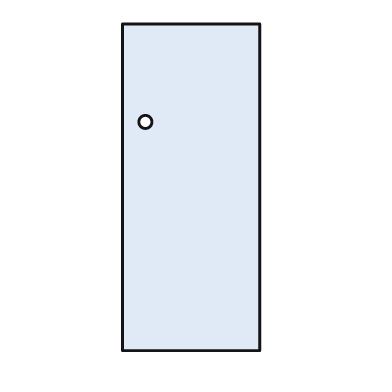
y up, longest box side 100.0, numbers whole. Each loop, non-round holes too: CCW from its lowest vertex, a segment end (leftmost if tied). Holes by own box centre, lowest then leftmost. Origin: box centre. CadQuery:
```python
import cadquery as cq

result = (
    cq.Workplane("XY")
    .moveTo(-21.0, -50.0)
    .lineTo(21.0, -50.0)
    .lineTo(21.0, 50.0)
    .lineTo(-21.0, 50.0)
    .close()
    .moveTo(-14.0, 20.0)
    .circle(2.0)
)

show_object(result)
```